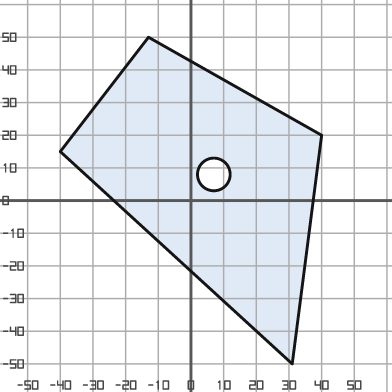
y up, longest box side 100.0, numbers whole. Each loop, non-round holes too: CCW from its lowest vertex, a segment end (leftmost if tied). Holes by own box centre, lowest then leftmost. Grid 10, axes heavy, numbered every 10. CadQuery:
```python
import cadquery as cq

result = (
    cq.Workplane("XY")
    .moveTo(31.0, -50.0)
    .lineTo(40.0, 20.0)
    .lineTo(-13.0, 50.0)
    .lineTo(-40.0, 15.0)
    .close()
    .moveTo(7.0, 8.0)
    .circle(5.0)
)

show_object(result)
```